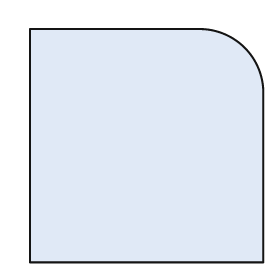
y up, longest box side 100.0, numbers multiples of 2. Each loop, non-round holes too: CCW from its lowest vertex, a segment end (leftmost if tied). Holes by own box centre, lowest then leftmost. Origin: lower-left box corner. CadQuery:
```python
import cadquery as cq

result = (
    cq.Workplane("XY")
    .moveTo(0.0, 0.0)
    .lineTo(100.0, 0.0)
    .lineTo(100.0, 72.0)
    .threePointArc((92.0, 92.0), (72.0, 100.0))
    .lineTo(0.0, 100.0)
    .close()
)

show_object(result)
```